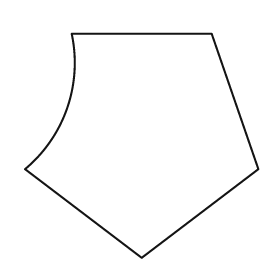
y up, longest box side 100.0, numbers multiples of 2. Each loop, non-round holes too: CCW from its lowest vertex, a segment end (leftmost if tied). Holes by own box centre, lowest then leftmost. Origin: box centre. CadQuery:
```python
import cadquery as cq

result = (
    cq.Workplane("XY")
    .moveTo(0.0, -48.0)
    .lineTo(50.0, -10.0)
    .lineTo(30.0, 48.0)
    .lineTo(-30.0, 48.0)
    .threePointArc((-32.0, 16.0), (-50.0, -10.0))
    .close()
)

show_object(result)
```